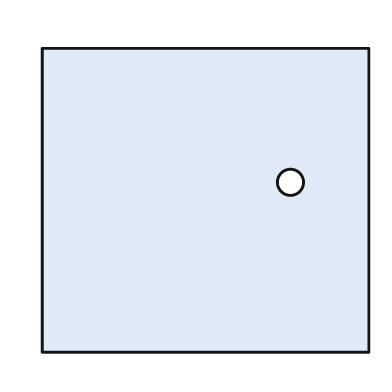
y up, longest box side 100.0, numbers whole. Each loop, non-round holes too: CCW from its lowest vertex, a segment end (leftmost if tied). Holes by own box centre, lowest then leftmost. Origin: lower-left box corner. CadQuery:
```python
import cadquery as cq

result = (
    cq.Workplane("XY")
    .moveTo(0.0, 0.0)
    .lineTo(100.0, 0.0)
    .lineTo(100.0, 93.0)
    .lineTo(0.0, 93.0)
    .close()
    .moveTo(76.0, 52.0)
    .circle(4.0)
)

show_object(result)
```